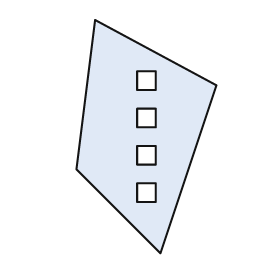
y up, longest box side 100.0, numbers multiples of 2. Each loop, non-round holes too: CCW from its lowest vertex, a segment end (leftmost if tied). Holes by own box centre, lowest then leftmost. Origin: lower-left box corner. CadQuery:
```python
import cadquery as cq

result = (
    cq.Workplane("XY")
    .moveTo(36.0, 0.0)
    .lineTo(60.0, 72.0)
    .lineTo(8.0, 100.0)
    .lineTo(0.0, 36.0)
    .close()
    .moveTo(26.0, 22.0)
    .lineTo(34.0, 22.0)
    .lineTo(34.0, 30.0)
    .lineTo(26.0, 30.0)
    .close()
    .moveTo(26.0, 38.0)
    .lineTo(34.0, 38.0)
    .lineTo(34.0, 46.0)
    .lineTo(26.0, 46.0)
    .close()
    .moveTo(26.0, 54.0)
    .lineTo(34.0, 54.0)
    .lineTo(34.0, 62.0)
    .lineTo(26.0, 62.0)
    .close()
    .moveTo(26.0, 70.0)
    .lineTo(34.0, 70.0)
    .lineTo(34.0, 78.0)
    .lineTo(26.0, 78.0)
    .close()
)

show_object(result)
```